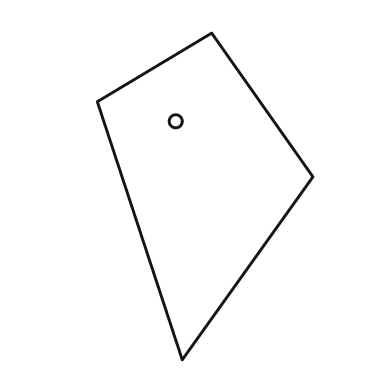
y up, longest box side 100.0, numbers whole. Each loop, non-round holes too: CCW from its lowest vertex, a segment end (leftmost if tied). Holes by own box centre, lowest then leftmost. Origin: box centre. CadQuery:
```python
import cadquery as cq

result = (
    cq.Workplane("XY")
    .moveTo(-7.0, -50.0)
    .lineTo(33.0, 6.0)
    .lineTo(2.0, 50.0)
    .lineTo(-33.0, 29.0)
    .close()
    .moveTo(-9.0, 23.0)
    .circle(2.0)
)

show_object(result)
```